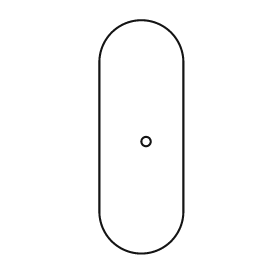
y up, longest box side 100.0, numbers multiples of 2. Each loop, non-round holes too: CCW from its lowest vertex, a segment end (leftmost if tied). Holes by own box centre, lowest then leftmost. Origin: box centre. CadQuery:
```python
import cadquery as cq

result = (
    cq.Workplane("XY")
    .moveTo(-18.0, -32.0)
    .threePointArc((0.0, -50.0), (18.0, -32.0))
    .lineTo(18.0, 32.0)
    .threePointArc((0.0, 50.0), (-18.0, 32.0))
    .close()
    .moveTo(2.0, -2.0)
    .circle(2.0)
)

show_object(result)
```